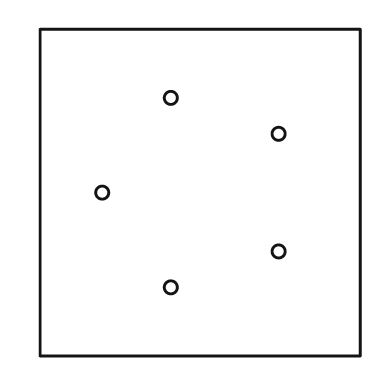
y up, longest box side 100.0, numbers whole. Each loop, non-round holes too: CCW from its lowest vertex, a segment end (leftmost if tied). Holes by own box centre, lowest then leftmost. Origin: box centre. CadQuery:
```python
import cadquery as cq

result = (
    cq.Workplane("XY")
    .moveTo(-49.0, -50.0)
    .lineTo(49.0, -50.0)
    .lineTo(49.0, 50.0)
    .lineTo(-49.0, 50.0)
    .close()
    .moveTo(-9.0, -29.0)
    .circle(2.0)
    .moveTo(24.0, -18.0)
    .circle(2.0)
    .moveTo(-30.0, 0.0)
    .circle(2.0)
    .moveTo(24.0, 18.0)
    .circle(2.0)
    .moveTo(-9.0, 29.0)
    .circle(2.0)
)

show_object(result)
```